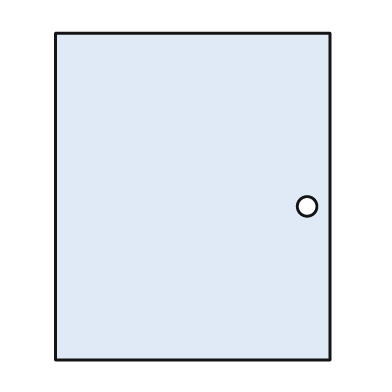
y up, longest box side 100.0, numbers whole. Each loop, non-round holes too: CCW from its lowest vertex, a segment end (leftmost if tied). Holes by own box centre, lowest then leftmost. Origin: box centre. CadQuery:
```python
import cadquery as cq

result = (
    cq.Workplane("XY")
    .moveTo(-42.0, -50.0)
    .lineTo(42.0, -50.0)
    .lineTo(42.0, 50.0)
    .lineTo(-42.0, 50.0)
    .close()
    .moveTo(35.0, -3.0)
    .circle(3.0)
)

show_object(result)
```